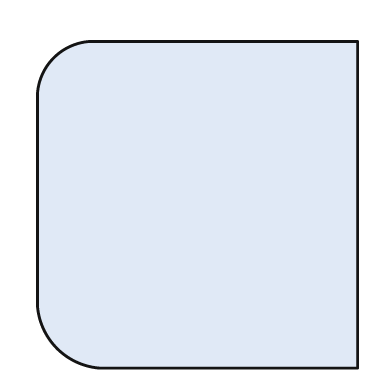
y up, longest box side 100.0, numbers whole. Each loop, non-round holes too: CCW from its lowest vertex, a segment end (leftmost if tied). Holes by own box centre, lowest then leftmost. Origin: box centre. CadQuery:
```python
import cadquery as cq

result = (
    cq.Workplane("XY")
    .moveTo(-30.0, -50.0)
    .lineTo(49.0, -50.0)
    .lineTo(49.0, 50.0)
    .lineTo(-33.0, 50.0)
    .threePointArc((-44.0, 45.0), (-49.0, 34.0))
    .lineTo(-49.0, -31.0)
    .threePointArc((-43.0, -44.0), (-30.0, -50.0))
    .close()
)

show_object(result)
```